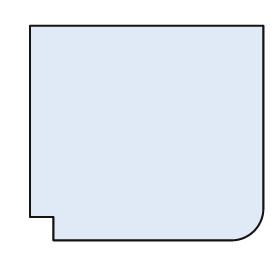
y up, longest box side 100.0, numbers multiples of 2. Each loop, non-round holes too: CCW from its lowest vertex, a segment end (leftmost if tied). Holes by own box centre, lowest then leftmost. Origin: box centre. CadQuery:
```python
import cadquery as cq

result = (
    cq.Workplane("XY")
    .moveTo(-40.0, -46.0)
    .lineTo(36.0, -46.0)
    .threePointArc((46.0, -42.0), (50.0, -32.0))
    .lineTo(50.0, 46.0)
    .lineTo(-50.0, 46.0)
    .lineTo(-50.0, -36.0)
    .lineTo(-40.0, -36.0)
    .close()
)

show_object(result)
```